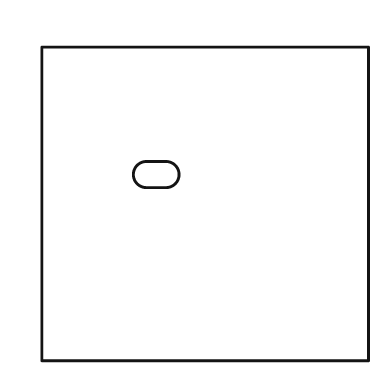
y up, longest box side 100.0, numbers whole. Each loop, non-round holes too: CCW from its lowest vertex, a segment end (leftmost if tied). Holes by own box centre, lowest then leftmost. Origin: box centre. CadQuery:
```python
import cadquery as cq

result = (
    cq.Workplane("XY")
    .moveTo(-50.0, -48.0)
    .lineTo(50.0, -48.0)
    .lineTo(50.0, 48.0)
    .lineTo(-50.0, 48.0)
    .close()
    .moveTo(-18.0, 5.0)
    .lineTo(-12.0, 5.0)
    .threePointArc((-8.0, 9.0), (-12.0, 13.0))
    .lineTo(-18.0, 13.0)
    .threePointArc((-22.0, 9.0), (-18.0, 5.0))
    .close()
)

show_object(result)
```